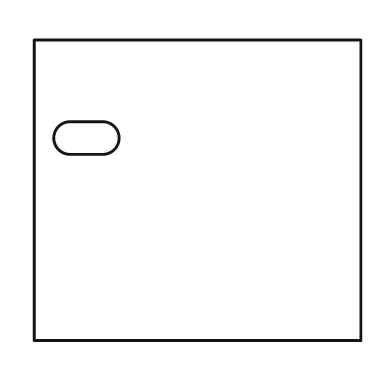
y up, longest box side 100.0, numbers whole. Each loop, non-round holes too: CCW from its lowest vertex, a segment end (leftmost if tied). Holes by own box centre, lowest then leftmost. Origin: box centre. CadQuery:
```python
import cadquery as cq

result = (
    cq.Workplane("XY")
    .moveTo(-50.0, -46.0)
    .lineTo(50.0, -46.0)
    .lineTo(50.0, 46.0)
    .lineTo(-50.0, 46.0)
    .close()
    .moveTo(-39.0, 11.0)
    .lineTo(-29.0, 11.0)
    .threePointArc((-24.0, 16.0), (-29.0, 21.0))
    .lineTo(-39.0, 21.0)
    .threePointArc((-44.0, 16.0), (-39.0, 11.0))
    .close()
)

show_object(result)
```